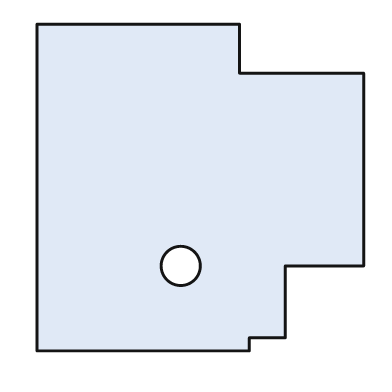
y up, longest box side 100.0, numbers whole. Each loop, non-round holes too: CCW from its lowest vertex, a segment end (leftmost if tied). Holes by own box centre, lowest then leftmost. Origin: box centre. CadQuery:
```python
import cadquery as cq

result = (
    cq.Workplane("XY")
    .moveTo(-50.0, -50.0)
    .lineTo(15.0, -50.0)
    .lineTo(15.0, -46.0)
    .lineTo(26.0, -46.0)
    .lineTo(26.0, -24.0)
    .lineTo(50.0, -24.0)
    .lineTo(50.0, 35.0)
    .lineTo(12.0, 35.0)
    .lineTo(12.0, 50.0)
    .lineTo(-50.0, 50.0)
    .close()
    .moveTo(-6.0, -24.0)
    .circle(6.0)
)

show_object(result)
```